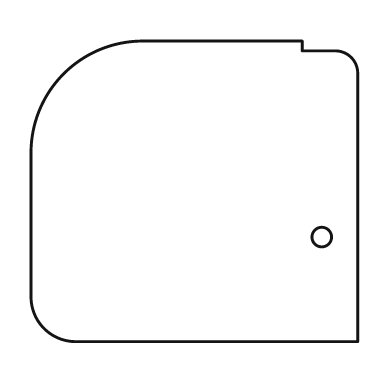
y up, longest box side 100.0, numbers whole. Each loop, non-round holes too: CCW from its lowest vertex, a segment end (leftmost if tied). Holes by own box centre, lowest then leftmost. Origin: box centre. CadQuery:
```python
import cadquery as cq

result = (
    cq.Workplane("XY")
    .moveTo(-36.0, -46.0)
    .lineTo(50.0, -46.0)
    .lineTo(50.0, 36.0)
    .threePointArc((48.0, 41.0), (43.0, 43.0))
    .lineTo(33.0, 43.0)
    .lineTo(33.0, 46.0)
    .lineTo(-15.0, 46.0)
    .threePointArc((-40.0, 36.0), (-50.0, 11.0))
    .lineTo(-50.0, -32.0)
    .threePointArc((-46.0, -42.0), (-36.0, -46.0))
    .close()
    .moveTo(39.0, -14.0)
    .circle(3.0)
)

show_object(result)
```